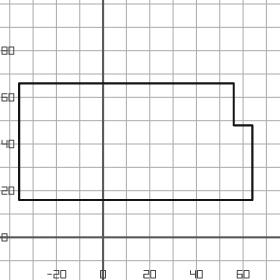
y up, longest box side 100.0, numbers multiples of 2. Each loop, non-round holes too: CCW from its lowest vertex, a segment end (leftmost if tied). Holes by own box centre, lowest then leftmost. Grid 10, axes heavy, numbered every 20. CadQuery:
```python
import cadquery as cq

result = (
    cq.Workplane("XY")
    .moveTo(-36.0, 16.0)
    .lineTo(64.0, 16.0)
    .lineTo(64.0, 48.0)
    .lineTo(56.0, 48.0)
    .lineTo(56.0, 66.0)
    .lineTo(-36.0, 66.0)
    .close()
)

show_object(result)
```